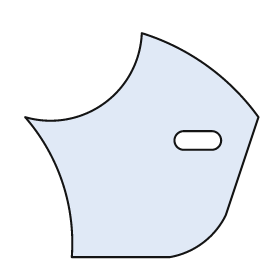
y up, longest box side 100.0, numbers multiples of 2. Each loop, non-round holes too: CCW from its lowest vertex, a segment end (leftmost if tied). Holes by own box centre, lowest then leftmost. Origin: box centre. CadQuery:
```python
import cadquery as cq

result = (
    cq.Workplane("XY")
    .moveTo(-30.0, -48.0)
    .lineTo(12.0, -48.0)
    .threePointArc((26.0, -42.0), (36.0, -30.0))
    .lineTo(50.0, 12.0)
    .threePointArc((28.0, 34.0), (0.0, 48.0))
    .threePointArc((-16.0, 18.0), (-50.0, 12.0))
    .threePointArc((-34.0, -16.0), (-30.0, -48.0))
    .close()
    .moveTo(18.0, -2.0)
    .lineTo(30.0, -2.0)
    .threePointArc((34.0, 2.0), (30.0, 6.0))
    .lineTo(18.0, 6.0)
    .threePointArc((14.0, 2.0), (18.0, -2.0))
    .close()
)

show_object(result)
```